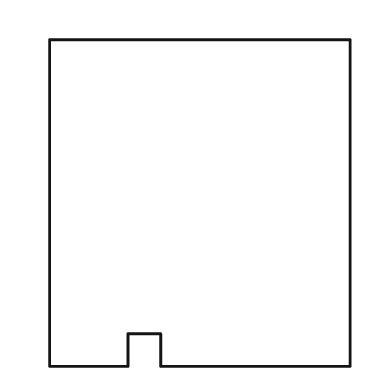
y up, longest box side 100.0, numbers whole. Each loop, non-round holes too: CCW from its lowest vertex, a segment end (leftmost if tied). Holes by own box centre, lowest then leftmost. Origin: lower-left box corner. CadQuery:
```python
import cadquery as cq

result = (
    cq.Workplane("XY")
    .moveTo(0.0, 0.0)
    .lineTo(24.0, 0.0)
    .lineTo(24.0, 10.0)
    .lineTo(34.0, 10.0)
    .lineTo(34.0, 0.0)
    .lineTo(92.0, 0.0)
    .lineTo(92.0, 100.0)
    .lineTo(0.0, 100.0)
    .close()
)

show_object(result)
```